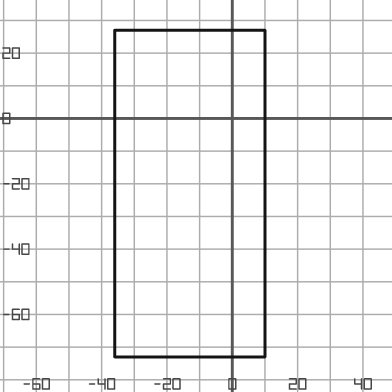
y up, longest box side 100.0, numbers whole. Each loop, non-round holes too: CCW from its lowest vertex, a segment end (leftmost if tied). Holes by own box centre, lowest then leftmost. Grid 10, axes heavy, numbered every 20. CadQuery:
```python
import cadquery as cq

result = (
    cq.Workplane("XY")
    .moveTo(-36.0, -73.0)
    .lineTo(10.0, -73.0)
    .lineTo(10.0, 27.0)
    .lineTo(-36.0, 27.0)
    .close()
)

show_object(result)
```